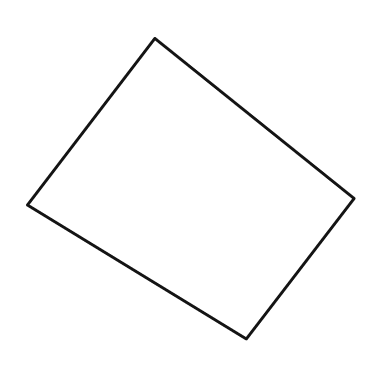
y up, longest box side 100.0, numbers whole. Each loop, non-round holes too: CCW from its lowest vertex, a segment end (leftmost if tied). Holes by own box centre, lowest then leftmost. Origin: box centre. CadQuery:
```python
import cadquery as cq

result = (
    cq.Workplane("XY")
    .moveTo(17.0, -46.0)
    .lineTo(50.0, -3.0)
    .lineTo(-11.0, 46.0)
    .lineTo(-50.0, -5.0)
    .close()
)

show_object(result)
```